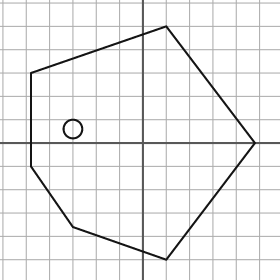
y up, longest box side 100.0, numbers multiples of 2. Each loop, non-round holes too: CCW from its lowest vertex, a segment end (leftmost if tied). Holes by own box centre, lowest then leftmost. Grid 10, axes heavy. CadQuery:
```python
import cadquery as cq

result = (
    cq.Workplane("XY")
    .moveTo(10.0, -50.0)
    .lineTo(48.0, 0.0)
    .lineTo(10.0, 50.0)
    .lineTo(-48.0, 30.0)
    .lineTo(-48.0, -10.0)
    .lineTo(-30.0, -36.0)
    .close()
    .moveTo(-30.0, 6.0)
    .circle(4.0)
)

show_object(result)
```